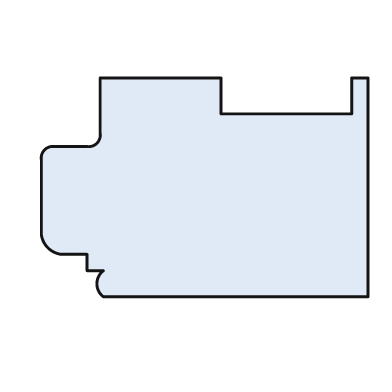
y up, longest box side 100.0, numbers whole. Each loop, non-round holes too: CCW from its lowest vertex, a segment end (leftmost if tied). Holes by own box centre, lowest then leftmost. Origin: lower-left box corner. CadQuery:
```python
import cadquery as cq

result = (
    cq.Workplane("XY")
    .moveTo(19.0, 0.0)
    .lineTo(100.0, 0.0)
    .lineTo(100.0, 67.0)
    .lineTo(95.0, 67.0)
    .lineTo(95.0, 56.0)
    .lineTo(55.0, 56.0)
    .lineTo(55.0, 67.0)
    .lineTo(18.0, 67.0)
    .lineTo(18.0, 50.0)
    .threePointArc((17.0, 47.0), (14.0, 46.0))
    .lineTo(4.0, 46.0)
    .threePointArc((1.0, 45.0), (0.0, 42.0))
    .lineTo(0.0, 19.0)
    .threePointArc((2.0, 15.0), (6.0, 13.0))
    .lineTo(14.0, 13.0)
    .lineTo(14.0, 8.0)
    .lineTo(19.0, 8.0)
    .threePointArc((17.0, 4.0), (19.0, 0.0))
    .close()
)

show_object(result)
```